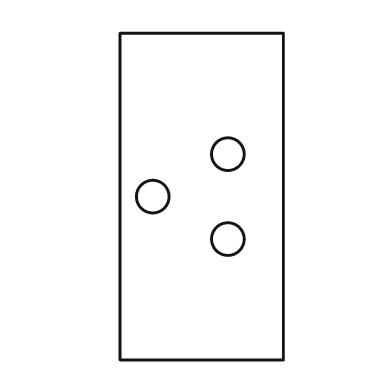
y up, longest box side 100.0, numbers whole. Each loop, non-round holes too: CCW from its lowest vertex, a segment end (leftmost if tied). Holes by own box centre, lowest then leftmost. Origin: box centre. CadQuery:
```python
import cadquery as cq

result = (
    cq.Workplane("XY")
    .moveTo(-25.0, -50.0)
    .lineTo(25.0, -50.0)
    .lineTo(25.0, 50.0)
    .lineTo(-25.0, 50.0)
    .close()
    .moveTo(8.0, -13.0)
    .circle(5.0)
    .moveTo(-15.0, 0.0)
    .circle(5.0)
    .moveTo(8.0, 13.0)
    .circle(5.0)
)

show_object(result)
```